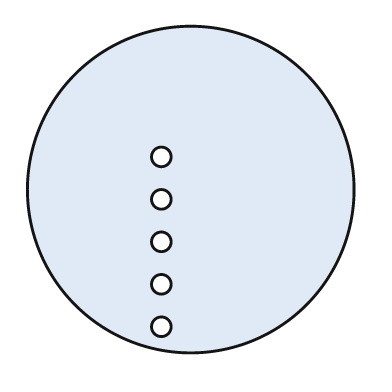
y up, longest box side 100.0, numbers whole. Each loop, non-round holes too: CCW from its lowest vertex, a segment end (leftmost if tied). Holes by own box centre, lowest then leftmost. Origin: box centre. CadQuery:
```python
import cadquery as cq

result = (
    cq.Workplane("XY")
    .moveTo(0.0, 0.0)
    .circle(50.0)
    .moveTo(-9.0, -42.0)
    .circle(3.0)
    .moveTo(-9.0, -29.0)
    .circle(3.0)
    .moveTo(-9.0, -16.0)
    .circle(3.0)
    .moveTo(-9.0, -3.0)
    .circle(3.0)
    .moveTo(-9.0, 10.0)
    .circle(3.0)
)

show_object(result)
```